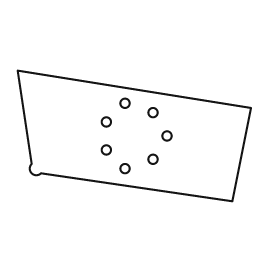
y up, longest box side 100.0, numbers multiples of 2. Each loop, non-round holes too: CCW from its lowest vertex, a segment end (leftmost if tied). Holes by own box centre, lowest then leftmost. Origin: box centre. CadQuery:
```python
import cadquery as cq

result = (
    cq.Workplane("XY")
    .moveTo(42.0, -28.0)
    .lineTo(50.0, 12.0)
    .lineTo(-50.0, 28.0)
    .lineTo(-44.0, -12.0)
    .threePointArc((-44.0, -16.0), (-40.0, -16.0))
    .close()
    .moveTo(-4.0, -14.0)
    .circle(2.0)
    .moveTo(8.0, -10.0)
    .circle(2.0)
    .moveTo(-12.0, -6.0)
    .circle(2.0)
    .moveTo(14.0, 0.0)
    .circle(2.0)
    .moveTo(-12.0, 6.0)
    .circle(2.0)
    .moveTo(8.0, 10.0)
    .circle(2.0)
    .moveTo(-4.0, 14.0)
    .circle(2.0)
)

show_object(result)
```